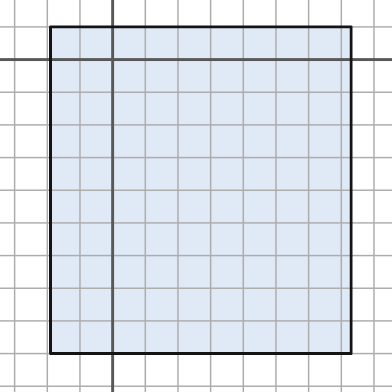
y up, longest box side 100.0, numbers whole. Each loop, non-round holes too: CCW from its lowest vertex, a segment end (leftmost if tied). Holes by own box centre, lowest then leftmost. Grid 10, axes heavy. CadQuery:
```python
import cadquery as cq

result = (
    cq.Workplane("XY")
    .moveTo(-19.0, -90.0)
    .lineTo(73.0, -90.0)
    .lineTo(73.0, 10.0)
    .lineTo(-19.0, 10.0)
    .close()
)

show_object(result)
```